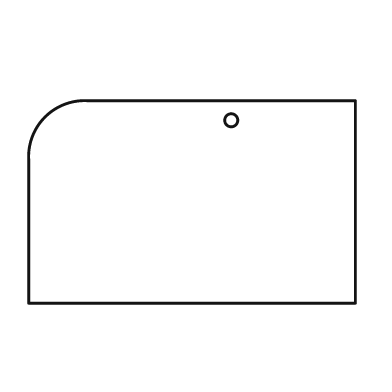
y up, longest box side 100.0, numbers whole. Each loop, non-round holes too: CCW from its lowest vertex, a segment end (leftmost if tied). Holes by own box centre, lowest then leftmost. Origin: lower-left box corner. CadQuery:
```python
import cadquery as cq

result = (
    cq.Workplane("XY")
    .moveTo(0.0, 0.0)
    .lineTo(100.0, 0.0)
    .lineTo(100.0, 62.0)
    .lineTo(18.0, 62.0)
    .threePointArc((5.0, 57.0), (0.0, 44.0))
    .close()
    .moveTo(62.0, 56.0)
    .circle(2.0)
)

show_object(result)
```